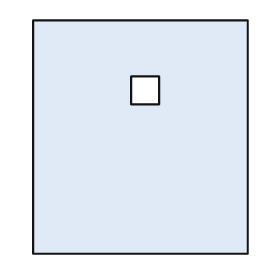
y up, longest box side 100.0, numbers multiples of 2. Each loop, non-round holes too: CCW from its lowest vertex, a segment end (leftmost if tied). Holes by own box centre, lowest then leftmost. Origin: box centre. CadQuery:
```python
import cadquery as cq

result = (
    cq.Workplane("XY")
    .moveTo(-46.0, -50.0)
    .lineTo(46.0, -50.0)
    .lineTo(46.0, 50.0)
    .lineTo(-46.0, 50.0)
    .close()
    .moveTo(-4.0, 14.0)
    .lineTo(8.0, 14.0)
    .lineTo(8.0, 26.0)
    .lineTo(-4.0, 26.0)
    .close()
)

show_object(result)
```